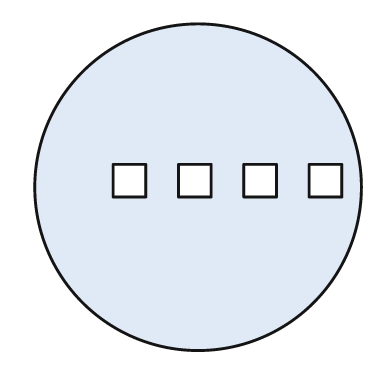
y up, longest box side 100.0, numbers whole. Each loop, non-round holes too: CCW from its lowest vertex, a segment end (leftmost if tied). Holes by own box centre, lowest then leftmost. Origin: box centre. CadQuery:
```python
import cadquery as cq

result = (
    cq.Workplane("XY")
    .moveTo(0.0, 0.0)
    .circle(50.0)
    .moveTo(-26.0, -3.0)
    .lineTo(-16.0, -3.0)
    .lineTo(-16.0, 7.0)
    .lineTo(-26.0, 7.0)
    .close()
    .moveTo(-6.0, -3.0)
    .lineTo(4.0, -3.0)
    .lineTo(4.0, 7.0)
    .lineTo(-6.0, 7.0)
    .close()
    .moveTo(14.0, -3.0)
    .lineTo(24.0, -3.0)
    .lineTo(24.0, 7.0)
    .lineTo(14.0, 7.0)
    .close()
    .moveTo(34.0, -3.0)
    .lineTo(44.0, -3.0)
    .lineTo(44.0, 7.0)
    .lineTo(34.0, 7.0)
    .close()
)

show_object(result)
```